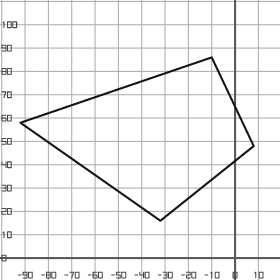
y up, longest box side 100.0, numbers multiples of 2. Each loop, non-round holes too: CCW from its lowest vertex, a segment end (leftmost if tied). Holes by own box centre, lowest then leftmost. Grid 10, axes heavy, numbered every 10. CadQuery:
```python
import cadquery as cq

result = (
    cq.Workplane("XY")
    .moveTo(-32.0, 16.0)
    .lineTo(8.0, 48.0)
    .lineTo(-10.0, 86.0)
    .lineTo(-92.0, 58.0)
    .close()
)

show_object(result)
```